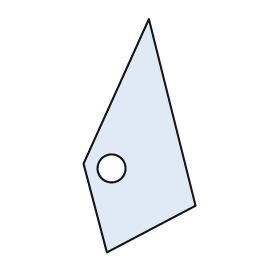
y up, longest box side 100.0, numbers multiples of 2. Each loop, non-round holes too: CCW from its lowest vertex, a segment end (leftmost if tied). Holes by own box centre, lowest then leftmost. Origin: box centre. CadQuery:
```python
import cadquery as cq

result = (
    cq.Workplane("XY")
    .moveTo(-14.0, -50.0)
    .lineTo(24.0, -30.0)
    .lineTo(4.0, 50.0)
    .lineTo(-24.0, -12.0)
    .close()
    .moveTo(-12.0, -14.0)
    .circle(6.0)
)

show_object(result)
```